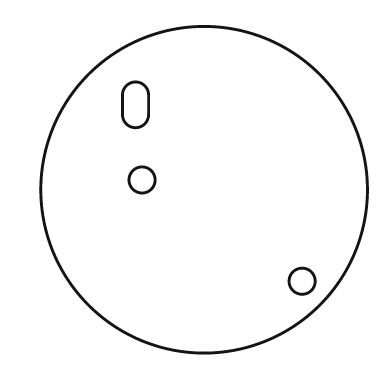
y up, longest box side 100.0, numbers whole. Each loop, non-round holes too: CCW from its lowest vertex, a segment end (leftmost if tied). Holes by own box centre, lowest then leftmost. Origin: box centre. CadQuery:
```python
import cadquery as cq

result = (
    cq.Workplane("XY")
    .moveTo(0.0, 0.0)
    .circle(50.0)
    .moveTo(30.0, -28.0)
    .circle(4.0)
    .moveTo(-19.0, 3.0)
    .circle(4.0)
    .moveTo(-25.0, 23.0)
    .threePointArc((-21.0, 19.0), (-17.0, 23.0))
    .lineTo(-17.0, 29.0)
    .threePointArc((-21.0, 33.0), (-25.0, 29.0))
    .close()
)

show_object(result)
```